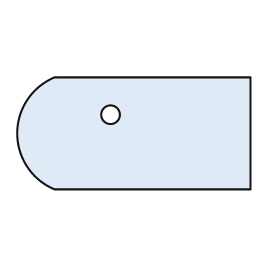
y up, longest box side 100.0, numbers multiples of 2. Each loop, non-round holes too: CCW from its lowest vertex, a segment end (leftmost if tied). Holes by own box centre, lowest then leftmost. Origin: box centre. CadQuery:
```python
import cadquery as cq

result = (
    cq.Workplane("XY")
    .moveTo(-34.0, -24.0)
    .lineTo(50.0, -24.0)
    .lineTo(50.0, 24.0)
    .lineTo(-34.0, 24.0)
    .threePointArc((-50.0, 0.0), (-34.0, -24.0))
    .close()
    .moveTo(-10.0, 8.0)
    .circle(4.0)
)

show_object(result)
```